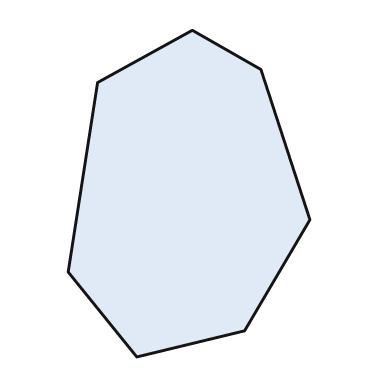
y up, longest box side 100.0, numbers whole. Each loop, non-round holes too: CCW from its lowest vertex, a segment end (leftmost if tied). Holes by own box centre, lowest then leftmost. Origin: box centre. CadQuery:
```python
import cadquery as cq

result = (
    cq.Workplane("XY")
    .moveTo(-16.0, -50.0)
    .lineTo(17.0, -42.0)
    .lineTo(37.0, -8.0)
    .lineTo(22.0, 38.0)
    .lineTo(1.0, 50.0)
    .lineTo(-28.0, 34.0)
    .lineTo(-37.0, -24.0)
    .close()
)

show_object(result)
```